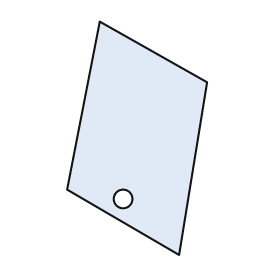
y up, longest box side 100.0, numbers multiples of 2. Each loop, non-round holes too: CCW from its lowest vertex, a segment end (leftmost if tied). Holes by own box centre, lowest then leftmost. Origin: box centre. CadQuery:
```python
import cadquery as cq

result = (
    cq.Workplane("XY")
    .moveTo(18.0, -50.0)
    .lineTo(30.0, 24.0)
    .lineTo(-16.0, 50.0)
    .lineTo(-30.0, -22.0)
    .close()
    .moveTo(-6.0, -26.0)
    .circle(4.0)
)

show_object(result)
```